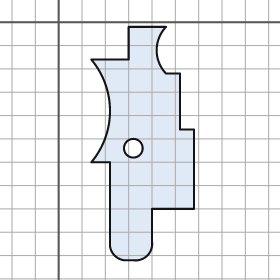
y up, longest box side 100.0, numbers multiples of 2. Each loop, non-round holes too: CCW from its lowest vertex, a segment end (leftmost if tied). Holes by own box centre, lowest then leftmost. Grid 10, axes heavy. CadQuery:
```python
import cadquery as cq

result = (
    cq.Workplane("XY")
    .moveTo(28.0, -102.0)
    .lineTo(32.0, -102.0)
    .threePointArc((38.0, -100.0), (40.0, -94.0))
    .lineTo(40.0, -80.0)
    .lineTo(58.0, -80.0)
    .lineTo(58.0, -46.0)
    .lineTo(52.0, -46.0)
    .lineTo(52.0, -22.0)
    .lineTo(46.0, -22.0)
    .threePointArc((42.0, -12.0), (46.0, -2.0))
    .lineTo(30.0, -2.0)
    .lineTo(30.0, -16.0)
    .lineTo(14.0, -16.0)
    .threePointArc((22.0, -38.0), (14.0, -60.0))
    .lineTo(22.0, -60.0)
    .lineTo(22.0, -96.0)
    .threePointArc((24.0, -100.0), (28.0, -102.0))
    .close()
    .moveTo(32.0, -54.0)
    .circle(4.0)
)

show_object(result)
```